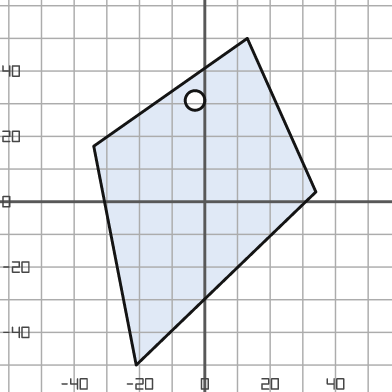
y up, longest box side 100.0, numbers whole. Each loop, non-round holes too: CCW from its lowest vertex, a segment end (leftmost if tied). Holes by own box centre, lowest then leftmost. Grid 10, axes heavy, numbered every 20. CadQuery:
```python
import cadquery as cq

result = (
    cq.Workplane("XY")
    .moveTo(-21.0, -50.0)
    .lineTo(34.0, 3.0)
    .lineTo(13.0, 50.0)
    .lineTo(-34.0, 17.0)
    .close()
    .moveTo(-3.0, 31.0)
    .circle(3.0)
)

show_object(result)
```